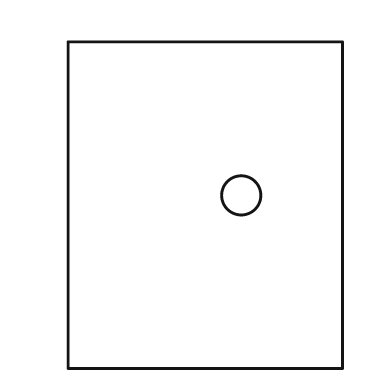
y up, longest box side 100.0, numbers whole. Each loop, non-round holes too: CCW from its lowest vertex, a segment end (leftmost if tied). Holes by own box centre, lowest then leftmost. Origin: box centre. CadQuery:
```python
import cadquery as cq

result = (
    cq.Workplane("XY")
    .moveTo(-42.0, -50.0)
    .lineTo(42.0, -50.0)
    .lineTo(42.0, 50.0)
    .lineTo(-42.0, 50.0)
    .close()
    .moveTo(11.0, 3.0)
    .circle(6.0)
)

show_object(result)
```